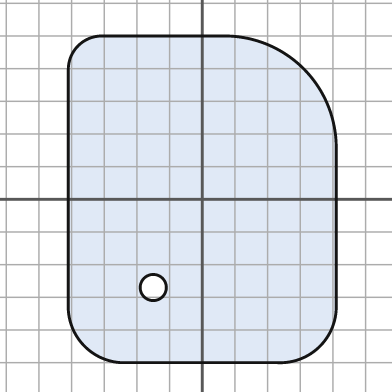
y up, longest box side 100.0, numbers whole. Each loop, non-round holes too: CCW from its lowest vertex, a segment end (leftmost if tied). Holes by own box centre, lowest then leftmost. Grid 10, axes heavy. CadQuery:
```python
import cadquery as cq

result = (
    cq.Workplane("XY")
    .moveTo(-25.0, -50.0)
    .lineTo(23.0, -50.0)
    .threePointArc((36.0, -45.0), (41.0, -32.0))
    .lineTo(41.0, 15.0)
    .threePointArc((31.0, 40.0), (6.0, 50.0))
    .lineTo(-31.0, 50.0)
    .threePointArc((-38.0, 47.0), (-41.0, 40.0))
    .lineTo(-41.0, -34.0)
    .threePointArc((-36.0, -45.0), (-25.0, -50.0))
    .close()
    .moveTo(-15.0, -27.0)
    .circle(4.0)
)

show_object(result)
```